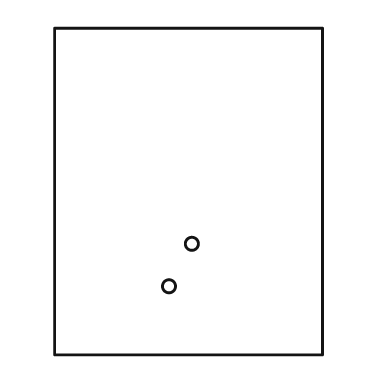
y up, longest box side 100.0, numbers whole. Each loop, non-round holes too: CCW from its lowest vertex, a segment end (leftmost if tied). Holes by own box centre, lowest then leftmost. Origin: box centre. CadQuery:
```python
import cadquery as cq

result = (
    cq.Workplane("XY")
    .moveTo(-41.0, -50.0)
    .lineTo(41.0, -50.0)
    .lineTo(41.0, 50.0)
    .lineTo(-41.0, 50.0)
    .close()
    .moveTo(-6.0, -29.0)
    .circle(2.0)
    .moveTo(1.0, -16.0)
    .circle(2.0)
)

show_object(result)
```